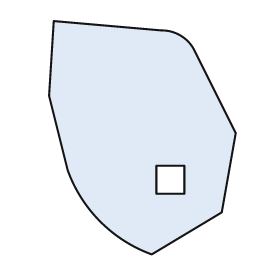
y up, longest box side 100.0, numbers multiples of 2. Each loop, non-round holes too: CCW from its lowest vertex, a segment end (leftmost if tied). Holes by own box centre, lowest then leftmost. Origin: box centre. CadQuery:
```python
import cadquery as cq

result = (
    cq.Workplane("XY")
    .moveTo(4.0, -50.0)
    .lineTo(34.0, -32.0)
    .lineTo(40.0, 2.0)
    .lineTo(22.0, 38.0)
    .threePointArc((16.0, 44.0), (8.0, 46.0))
    .lineTo(-38.0, 50.0)
    .lineTo(-40.0, 18.0)
    .lineTo(-32.0, -14.0)
    .threePointArc((-18.0, -36.0), (4.0, -50.0))
    .close()
    .moveTo(6.0, -24.0)
    .lineTo(18.0, -24.0)
    .lineTo(18.0, -12.0)
    .lineTo(6.0, -12.0)
    .close()
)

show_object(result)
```